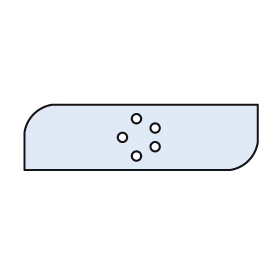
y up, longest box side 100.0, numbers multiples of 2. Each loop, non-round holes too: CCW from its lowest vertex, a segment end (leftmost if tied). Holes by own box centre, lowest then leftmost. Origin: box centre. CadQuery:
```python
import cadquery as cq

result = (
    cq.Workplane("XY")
    .moveTo(-50.0, -14.0)
    .lineTo(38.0, -14.0)
    .threePointArc((46.0, -10.0), (50.0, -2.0))
    .lineTo(50.0, 14.0)
    .lineTo(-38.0, 14.0)
    .threePointArc((-46.0, 10.0), (-50.0, 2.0))
    .close()
    .moveTo(-2.0, -8.0)
    .circle(2.0)
    .moveTo(6.0, -4.0)
    .circle(2.0)
    .moveTo(-8.0, 0.0)
    .circle(2.0)
    .moveTo(6.0, 4.0)
    .circle(2.0)
    .moveTo(-2.0, 8.0)
    .circle(2.0)
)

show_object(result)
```